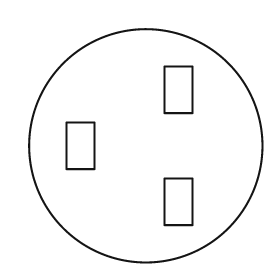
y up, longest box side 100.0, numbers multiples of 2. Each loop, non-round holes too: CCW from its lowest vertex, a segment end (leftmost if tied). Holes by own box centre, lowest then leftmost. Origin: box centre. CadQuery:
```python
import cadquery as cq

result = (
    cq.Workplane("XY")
    .moveTo(0.0, 0.0)
    .circle(50.0)
    .moveTo(8.0, -34.0)
    .lineTo(20.0, -34.0)
    .lineTo(20.0, -14.0)
    .lineTo(8.0, -14.0)
    .close()
    .moveTo(-34.0, -10.0)
    .lineTo(-22.0, -10.0)
    .lineTo(-22.0, 10.0)
    .lineTo(-34.0, 10.0)
    .close()
    .moveTo(8.0, 14.0)
    .lineTo(20.0, 14.0)
    .lineTo(20.0, 34.0)
    .lineTo(8.0, 34.0)
    .close()
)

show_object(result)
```